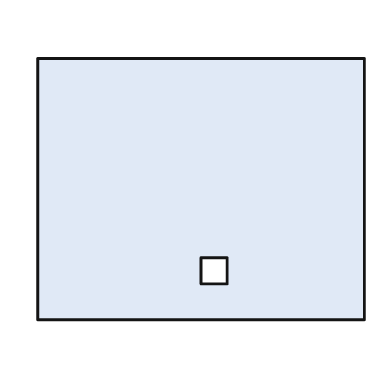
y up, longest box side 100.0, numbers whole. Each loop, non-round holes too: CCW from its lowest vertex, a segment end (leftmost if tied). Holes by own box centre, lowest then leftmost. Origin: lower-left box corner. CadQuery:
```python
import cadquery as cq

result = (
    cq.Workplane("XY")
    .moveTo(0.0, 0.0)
    .lineTo(100.0, 0.0)
    .lineTo(100.0, 80.0)
    .lineTo(0.0, 80.0)
    .close()
    .moveTo(50.0, 11.0)
    .lineTo(58.0, 11.0)
    .lineTo(58.0, 19.0)
    .lineTo(50.0, 19.0)
    .close()
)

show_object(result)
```